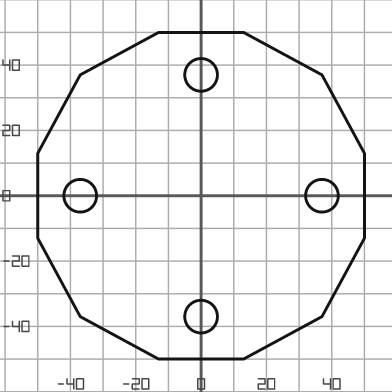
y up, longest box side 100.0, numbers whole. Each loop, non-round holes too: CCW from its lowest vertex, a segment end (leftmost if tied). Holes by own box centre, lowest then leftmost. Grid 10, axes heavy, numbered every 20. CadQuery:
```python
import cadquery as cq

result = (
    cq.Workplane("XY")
    .moveTo(-13.0, -50.0)
    .lineTo(13.0, -50.0)
    .lineTo(37.0, -37.0)
    .lineTo(50.0, -13.0)
    .lineTo(50.0, 13.0)
    .lineTo(37.0, 37.0)
    .lineTo(13.0, 50.0)
    .lineTo(-13.0, 50.0)
    .lineTo(-37.0, 37.0)
    .lineTo(-50.0, 13.0)
    .lineTo(-50.0, -13.0)
    .lineTo(-37.0, -37.0)
    .close()
    .moveTo(0.0, -37.0)
    .circle(5.0)
    .moveTo(-37.0, 0.0)
    .circle(5.0)
    .moveTo(37.0, 0.0)
    .circle(5.0)
    .moveTo(0.0, 37.0)
    .circle(5.0)
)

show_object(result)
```